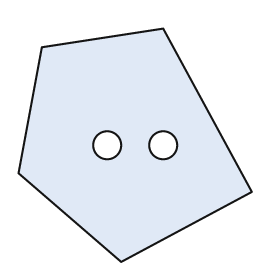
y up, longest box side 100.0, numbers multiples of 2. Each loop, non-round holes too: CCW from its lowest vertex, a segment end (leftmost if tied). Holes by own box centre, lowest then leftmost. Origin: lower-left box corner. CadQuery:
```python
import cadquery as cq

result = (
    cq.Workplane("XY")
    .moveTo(44.0, 0.0)
    .lineTo(100.0, 30.0)
    .lineTo(62.0, 100.0)
    .lineTo(10.0, 92.0)
    .lineTo(0.0, 38.0)
    .close()
    .moveTo(38.0, 50.0)
    .circle(6.0)
    .moveTo(62.0, 50.0)
    .circle(6.0)
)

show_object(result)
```